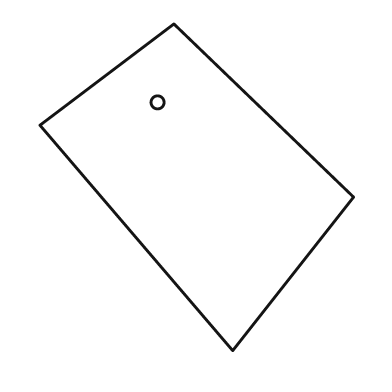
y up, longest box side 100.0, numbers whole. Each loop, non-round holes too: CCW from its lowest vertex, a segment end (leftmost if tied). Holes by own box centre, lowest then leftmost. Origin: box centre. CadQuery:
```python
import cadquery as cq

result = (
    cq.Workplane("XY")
    .moveTo(11.0, -50.0)
    .lineTo(48.0, -3.0)
    .lineTo(-7.0, 50.0)
    .lineTo(-48.0, 19.0)
    .close()
    .moveTo(-12.0, 26.0)
    .circle(2.0)
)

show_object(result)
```